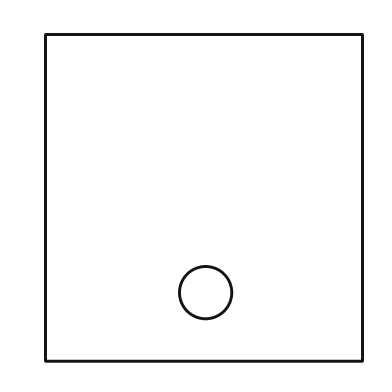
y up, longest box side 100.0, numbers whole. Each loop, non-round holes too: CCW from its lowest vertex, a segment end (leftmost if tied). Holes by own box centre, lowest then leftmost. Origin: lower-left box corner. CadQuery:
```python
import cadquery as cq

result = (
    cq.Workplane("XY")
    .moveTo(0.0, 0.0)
    .lineTo(97.0, 0.0)
    .lineTo(97.0, 100.0)
    .lineTo(0.0, 100.0)
    .close()
    .moveTo(49.0, 21.0)
    .circle(8.0)
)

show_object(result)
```